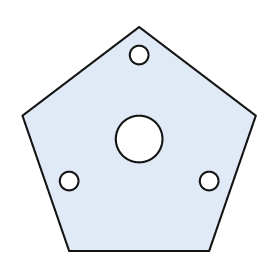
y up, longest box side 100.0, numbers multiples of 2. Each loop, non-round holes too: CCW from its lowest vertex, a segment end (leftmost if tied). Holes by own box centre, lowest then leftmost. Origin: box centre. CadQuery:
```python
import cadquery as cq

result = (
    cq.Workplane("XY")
    .moveTo(-30.0, -48.0)
    .lineTo(30.0, -48.0)
    .lineTo(50.0, 10.0)
    .lineTo(0.0, 48.0)
    .lineTo(-50.0, 10.0)
    .close()
    .moveTo(-30.0, -18.0)
    .circle(4.0)
    .moveTo(30.0, -18.0)
    .circle(4.0)
    .moveTo(0.0, 0.0)
    .circle(10.0)
    .moveTo(0.0, 36.0)
    .circle(4.0)
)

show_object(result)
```